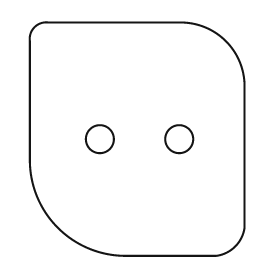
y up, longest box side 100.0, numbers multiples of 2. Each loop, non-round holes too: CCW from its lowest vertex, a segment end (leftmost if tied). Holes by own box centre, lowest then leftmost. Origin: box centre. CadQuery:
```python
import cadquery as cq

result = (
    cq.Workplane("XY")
    .moveTo(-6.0, -50.0)
    .lineTo(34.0, -50.0)
    .threePointArc((42.0, -46.0), (46.0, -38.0))
    .lineTo(46.0, 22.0)
    .threePointArc((38.0, 42.0), (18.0, 50.0))
    .lineTo(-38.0, 50.0)
    .threePointArc((-44.0, 48.0), (-46.0, 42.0))
    .lineTo(-46.0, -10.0)
    .threePointArc((-34.0, -38.0), (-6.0, -50.0))
    .close()
    .moveTo(-16.0, 0.0)
    .circle(6.0)
    .moveTo(18.0, 0.0)
    .circle(6.0)
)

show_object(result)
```